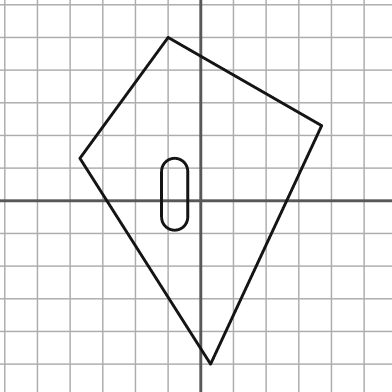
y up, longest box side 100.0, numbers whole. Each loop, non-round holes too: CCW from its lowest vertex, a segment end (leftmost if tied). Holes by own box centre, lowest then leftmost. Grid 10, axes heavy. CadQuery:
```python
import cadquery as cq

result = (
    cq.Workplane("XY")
    .moveTo(3.0, -50.0)
    .lineTo(37.0, 23.0)
    .lineTo(-10.0, 50.0)
    .lineTo(-37.0, 13.0)
    .close()
    .moveTo(-12.0, -5.0)
    .threePointArc((-8.0, -9.0), (-4.0, -5.0))
    .lineTo(-4.0, 9.0)
    .threePointArc((-8.0, 13.0), (-12.0, 9.0))
    .close()
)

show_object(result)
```